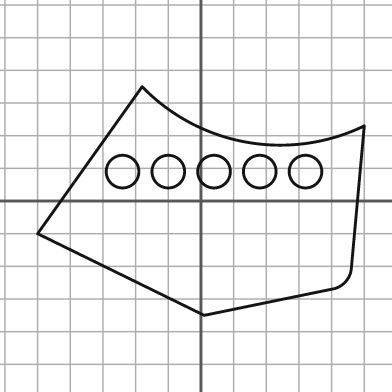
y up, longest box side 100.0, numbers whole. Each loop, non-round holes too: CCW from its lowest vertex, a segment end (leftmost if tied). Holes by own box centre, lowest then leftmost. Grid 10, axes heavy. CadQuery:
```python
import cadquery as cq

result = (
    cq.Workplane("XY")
    .moveTo(1.0, -35.0)
    .lineTo(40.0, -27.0)
    .threePointArc((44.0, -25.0), (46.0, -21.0))
    .lineTo(50.0, 23.0)
    .threePointArc((14.0, 18.0), (-18.0, 35.0))
    .lineTo(-50.0, -10.0)
    .close()
    .moveTo(-24.0, 9.0)
    .circle(5.0)
    .moveTo(-10.0, 9.0)
    .circle(5.0)
    .moveTo(4.0, 9.0)
    .circle(5.0)
    .moveTo(18.0, 9.0)
    .circle(5.0)
    .moveTo(32.0, 9.0)
    .circle(5.0)
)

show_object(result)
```